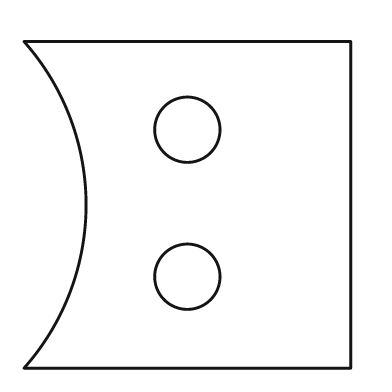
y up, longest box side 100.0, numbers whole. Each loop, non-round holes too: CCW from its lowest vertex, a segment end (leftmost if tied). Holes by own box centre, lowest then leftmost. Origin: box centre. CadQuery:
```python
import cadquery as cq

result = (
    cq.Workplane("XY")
    .moveTo(-50.0, -50.0)
    .lineTo(50.0, -50.0)
    .lineTo(50.0, 50.0)
    .lineTo(-50.0, 50.0)
    .threePointArc((-31.0, 0.0), (-50.0, -50.0))
    .close()
    .moveTo(0.0, -22.0)
    .circle(10.0)
    .moveTo(0.0, 23.0)
    .circle(10.0)
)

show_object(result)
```